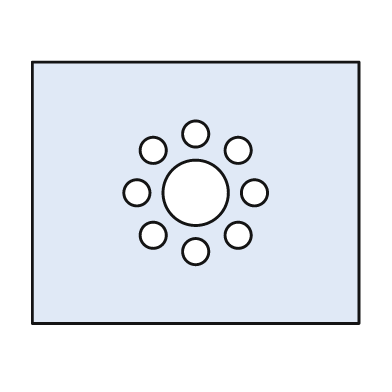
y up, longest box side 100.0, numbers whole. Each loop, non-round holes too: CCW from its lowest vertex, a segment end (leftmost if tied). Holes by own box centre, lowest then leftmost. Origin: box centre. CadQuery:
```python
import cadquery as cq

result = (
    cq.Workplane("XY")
    .moveTo(-50.0, -40.0)
    .lineTo(50.0, -40.0)
    .lineTo(50.0, 40.0)
    .lineTo(-50.0, 40.0)
    .close()
    .moveTo(0.0, -18.0)
    .circle(4.0)
    .moveTo(-13.0, -13.0)
    .circle(4.0)
    .moveTo(13.0, -13.0)
    .circle(4.0)
    .moveTo(-18.0, 0.0)
    .circle(4.0)
    .moveTo(0.0, 0.0)
    .circle(10.0)
    .moveTo(18.0, 0.0)
    .circle(4.0)
    .moveTo(-13.0, 13.0)
    .circle(4.0)
    .moveTo(13.0, 13.0)
    .circle(4.0)
    .moveTo(0.0, 18.0)
    .circle(4.0)
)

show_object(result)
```